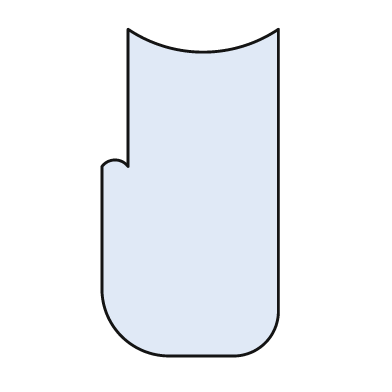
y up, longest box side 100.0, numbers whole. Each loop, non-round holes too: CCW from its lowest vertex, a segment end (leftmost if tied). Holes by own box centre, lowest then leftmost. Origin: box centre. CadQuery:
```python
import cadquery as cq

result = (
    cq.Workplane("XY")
    .moveTo(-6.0, -50.0)
    .lineTo(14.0, -50.0)
    .threePointArc((23.0, -46.0), (27.0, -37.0))
    .lineTo(27.0, 50.0)
    .threePointArc((4.0, 43.0), (-19.0, 50.0))
    .lineTo(-19.0, 8.0)
    .threePointArc((-23.0, 10.0), (-27.0, 8.0))
    .lineTo(-27.0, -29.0)
    .threePointArc((-21.0, -44.0), (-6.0, -50.0))
    .close()
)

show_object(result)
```